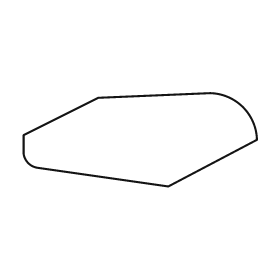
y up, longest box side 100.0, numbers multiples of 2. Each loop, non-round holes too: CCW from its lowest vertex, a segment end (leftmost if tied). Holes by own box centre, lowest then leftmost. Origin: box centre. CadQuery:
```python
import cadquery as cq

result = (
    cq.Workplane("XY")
    .moveTo(12.0, -20.0)
    .lineTo(50.0, 0.0)
    .threePointArc((44.0, 14.0), (30.0, 20.0))
    .lineTo(-18.0, 18.0)
    .lineTo(-50.0, 2.0)
    .lineTo(-50.0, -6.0)
    .threePointArc((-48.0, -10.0), (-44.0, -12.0))
    .close()
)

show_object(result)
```